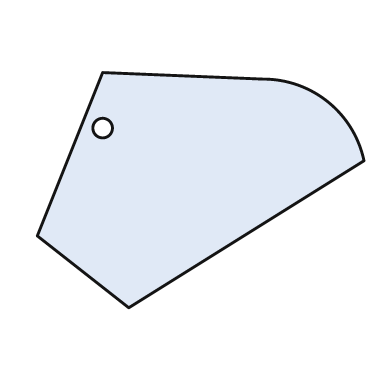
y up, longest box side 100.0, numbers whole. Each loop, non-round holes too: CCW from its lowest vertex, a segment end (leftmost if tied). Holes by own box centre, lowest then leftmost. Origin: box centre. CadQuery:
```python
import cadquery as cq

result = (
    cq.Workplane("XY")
    .moveTo(-22.0, -36.0)
    .lineTo(50.0, 9.0)
    .threePointArc((39.0, 27.0), (19.0, 34.0))
    .lineTo(-30.0, 36.0)
    .lineTo(-50.0, -14.0)
    .close()
    .moveTo(-30.0, 19.0)
    .circle(3.0)
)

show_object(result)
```